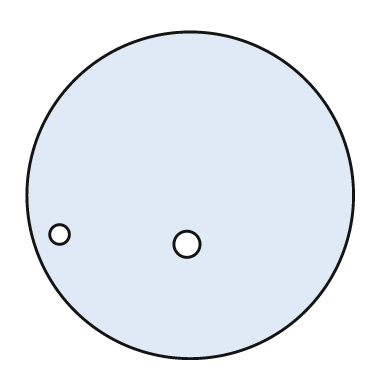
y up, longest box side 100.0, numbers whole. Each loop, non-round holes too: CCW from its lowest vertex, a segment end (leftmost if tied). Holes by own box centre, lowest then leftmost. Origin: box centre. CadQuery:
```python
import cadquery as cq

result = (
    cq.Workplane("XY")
    .moveTo(0.0, 0.0)
    .circle(50.0)
    .moveTo(-1.0, -15.0)
    .circle(4.0)
    .moveTo(-40.0, -12.0)
    .circle(3.0)
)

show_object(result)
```